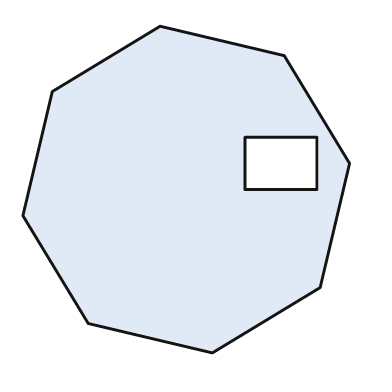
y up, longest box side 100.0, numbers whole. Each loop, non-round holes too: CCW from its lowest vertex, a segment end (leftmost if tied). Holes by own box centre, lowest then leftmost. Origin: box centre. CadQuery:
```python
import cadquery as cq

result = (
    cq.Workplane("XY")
    .moveTo(8.0, -50.0)
    .lineTo(41.0, -30.0)
    .lineTo(50.0, 8.0)
    .lineTo(30.0, 41.0)
    .lineTo(-8.0, 50.0)
    .lineTo(-41.0, 30.0)
    .lineTo(-50.0, -8.0)
    .lineTo(-30.0, -41.0)
    .close()
    .moveTo(18.0, 0.0)
    .lineTo(40.0, 0.0)
    .lineTo(40.0, 16.0)
    .lineTo(18.0, 16.0)
    .close()
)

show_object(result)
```